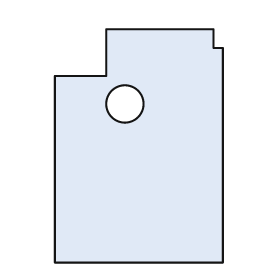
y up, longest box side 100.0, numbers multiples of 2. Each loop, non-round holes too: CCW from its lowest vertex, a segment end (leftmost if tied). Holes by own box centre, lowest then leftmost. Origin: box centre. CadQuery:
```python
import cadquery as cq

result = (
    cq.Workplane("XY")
    .moveTo(-36.0, -50.0)
    .lineTo(36.0, -50.0)
    .lineTo(36.0, 42.0)
    .lineTo(32.0, 42.0)
    .lineTo(32.0, 50.0)
    .lineTo(-14.0, 50.0)
    .lineTo(-14.0, 30.0)
    .lineTo(-36.0, 30.0)
    .close()
    .moveTo(-6.0, 18.0)
    .circle(8.0)
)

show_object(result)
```